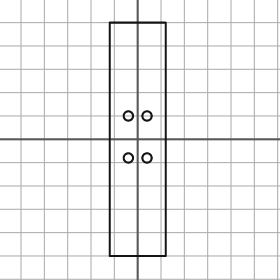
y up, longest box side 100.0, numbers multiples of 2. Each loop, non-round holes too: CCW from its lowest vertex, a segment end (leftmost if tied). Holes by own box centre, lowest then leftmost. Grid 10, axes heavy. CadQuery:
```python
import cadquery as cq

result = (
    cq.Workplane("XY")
    .moveTo(-12.0, -50.0)
    .lineTo(12.0, -50.0)
    .lineTo(12.0, 50.0)
    .lineTo(-12.0, 50.0)
    .close()
    .moveTo(-4.0, -8.0)
    .circle(2.0)
    .moveTo(4.0, -8.0)
    .circle(2.0)
    .moveTo(-4.0, 10.0)
    .circle(2.0)
    .moveTo(4.0, 10.0)
    .circle(2.0)
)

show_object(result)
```